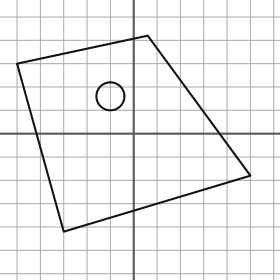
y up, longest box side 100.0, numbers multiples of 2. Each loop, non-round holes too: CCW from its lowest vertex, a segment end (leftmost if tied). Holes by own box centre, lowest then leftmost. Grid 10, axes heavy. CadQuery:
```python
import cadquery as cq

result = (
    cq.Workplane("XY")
    .moveTo(-30.0, -42.0)
    .lineTo(50.0, -18.0)
    .lineTo(6.0, 42.0)
    .lineTo(-50.0, 30.0)
    .close()
    .moveTo(-10.0, 16.0)
    .circle(6.0)
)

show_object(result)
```